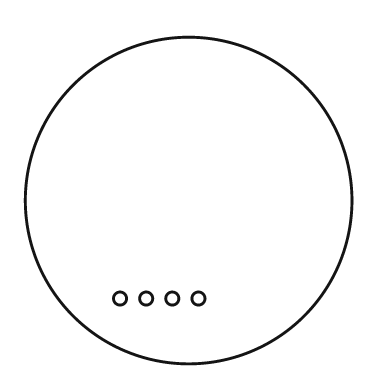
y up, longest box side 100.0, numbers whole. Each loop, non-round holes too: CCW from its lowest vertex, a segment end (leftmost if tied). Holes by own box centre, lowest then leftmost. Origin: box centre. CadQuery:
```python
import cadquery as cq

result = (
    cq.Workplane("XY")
    .moveTo(0.0, 0.0)
    .circle(50.0)
    .moveTo(-21.0, -30.0)
    .circle(2.0)
    .moveTo(-13.0, -30.0)
    .circle(2.0)
    .moveTo(-5.0, -30.0)
    .circle(2.0)
    .moveTo(3.0, -30.0)
    .circle(2.0)
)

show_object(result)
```